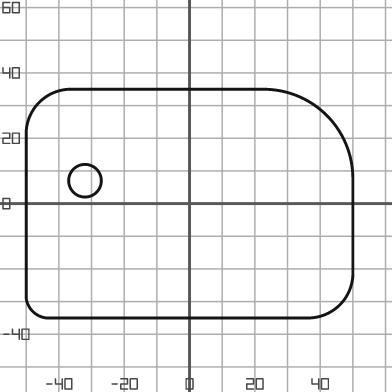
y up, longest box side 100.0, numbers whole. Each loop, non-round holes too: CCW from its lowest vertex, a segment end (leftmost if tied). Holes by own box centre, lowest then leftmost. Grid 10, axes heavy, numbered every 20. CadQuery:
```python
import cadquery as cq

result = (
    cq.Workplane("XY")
    .moveTo(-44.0, -35.0)
    .lineTo(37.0, -35.0)
    .threePointArc((46.0, -31.0), (50.0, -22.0))
    .lineTo(50.0, 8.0)
    .threePointArc((42.0, 27.0), (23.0, 35.0))
    .lineTo(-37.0, 35.0)
    .threePointArc((-46.0, 31.0), (-50.0, 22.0))
    .lineTo(-50.0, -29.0)
    .threePointArc((-48.0, -33.0), (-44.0, -35.0))
    .close()
    .moveTo(-32.0, 7.0)
    .circle(5.0)
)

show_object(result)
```